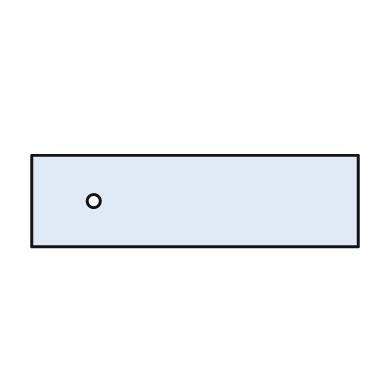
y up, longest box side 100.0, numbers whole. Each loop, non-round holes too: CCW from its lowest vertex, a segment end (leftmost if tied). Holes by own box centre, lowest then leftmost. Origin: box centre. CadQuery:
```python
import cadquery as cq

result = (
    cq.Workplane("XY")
    .moveTo(-50.0, -14.0)
    .lineTo(50.0, -14.0)
    .lineTo(50.0, 14.0)
    .lineTo(-50.0, 14.0)
    .close()
    .moveTo(-31.0, 0.0)
    .circle(2.0)
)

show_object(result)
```